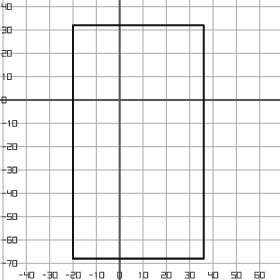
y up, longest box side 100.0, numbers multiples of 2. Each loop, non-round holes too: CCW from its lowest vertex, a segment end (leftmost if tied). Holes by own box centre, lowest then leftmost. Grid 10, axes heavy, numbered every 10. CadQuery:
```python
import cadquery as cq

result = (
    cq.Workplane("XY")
    .moveTo(-20.0, -68.0)
    .lineTo(36.0, -68.0)
    .lineTo(36.0, 32.0)
    .lineTo(-20.0, 32.0)
    .close()
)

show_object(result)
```